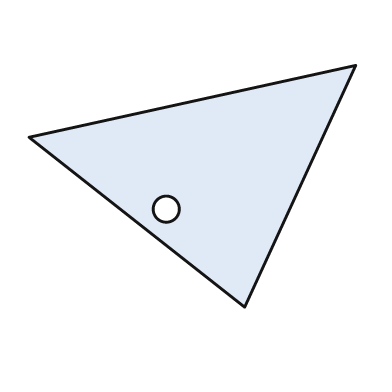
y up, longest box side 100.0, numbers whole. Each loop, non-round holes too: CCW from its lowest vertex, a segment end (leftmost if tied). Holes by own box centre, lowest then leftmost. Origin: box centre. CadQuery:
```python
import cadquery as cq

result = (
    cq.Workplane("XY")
    .moveTo(16.0, -37.0)
    .lineTo(50.0, 37.0)
    .lineTo(-50.0, 15.0)
    .close()
    .moveTo(-8.0, -7.0)
    .circle(4.0)
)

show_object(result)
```